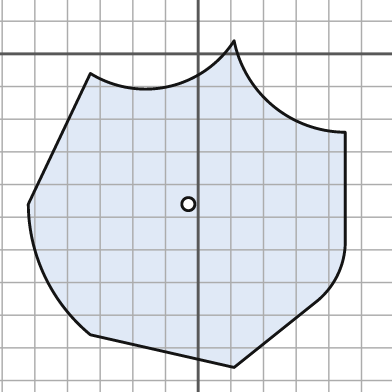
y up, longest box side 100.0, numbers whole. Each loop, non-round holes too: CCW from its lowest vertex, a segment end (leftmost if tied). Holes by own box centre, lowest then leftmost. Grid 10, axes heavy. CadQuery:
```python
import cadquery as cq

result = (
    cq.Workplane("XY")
    .moveTo(11.0, -96.0)
    .lineTo(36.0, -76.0)
    .threePointArc((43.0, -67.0), (45.0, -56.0))
    .lineTo(45.0, -24.0)
    .threePointArc((23.0, -16.0), (11.0, 4.0))
    .threePointArc((-9.0, -10.0), (-33.0, -6.0))
    .lineTo(-52.0, -46.0)
    .threePointArc((-47.0, -68.0), (-33.0, -86.0))
    .close()
    .moveTo(-3.0, -46.0)
    .circle(2.0)
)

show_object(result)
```